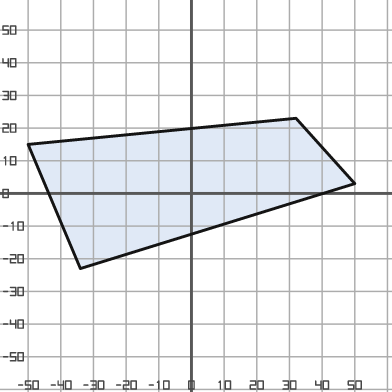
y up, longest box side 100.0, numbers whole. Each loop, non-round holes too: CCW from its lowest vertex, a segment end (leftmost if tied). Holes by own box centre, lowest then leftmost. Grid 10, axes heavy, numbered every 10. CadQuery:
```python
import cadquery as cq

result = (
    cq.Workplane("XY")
    .moveTo(-34.0, -23.0)
    .lineTo(50.0, 3.0)
    .lineTo(32.0, 23.0)
    .lineTo(-50.0, 15.0)
    .close()
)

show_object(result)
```